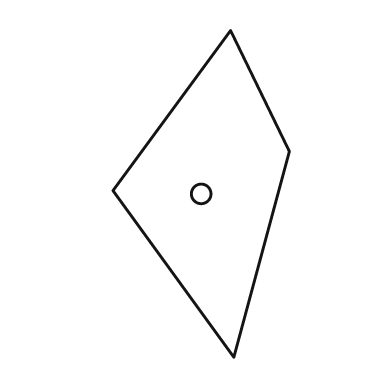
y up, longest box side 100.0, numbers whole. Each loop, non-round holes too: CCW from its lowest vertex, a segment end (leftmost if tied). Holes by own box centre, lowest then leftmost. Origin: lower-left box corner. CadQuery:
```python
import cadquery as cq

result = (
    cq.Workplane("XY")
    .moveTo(37.0, 0.0)
    .lineTo(54.0, 63.0)
    .lineTo(36.0, 100.0)
    .lineTo(0.0, 51.0)
    .close()
    .moveTo(27.0, 50.0)
    .circle(3.0)
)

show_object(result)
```